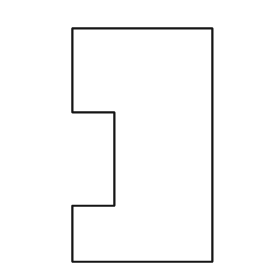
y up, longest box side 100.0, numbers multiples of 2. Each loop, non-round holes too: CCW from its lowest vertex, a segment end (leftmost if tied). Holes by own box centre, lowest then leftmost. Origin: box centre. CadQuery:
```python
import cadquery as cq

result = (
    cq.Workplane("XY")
    .moveTo(-30.0, -50.0)
    .lineTo(30.0, -50.0)
    .lineTo(30.0, 50.0)
    .lineTo(-30.0, 50.0)
    .lineTo(-30.0, 14.0)
    .lineTo(-12.0, 14.0)
    .lineTo(-12.0, -26.0)
    .lineTo(-30.0, -26.0)
    .close()
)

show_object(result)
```